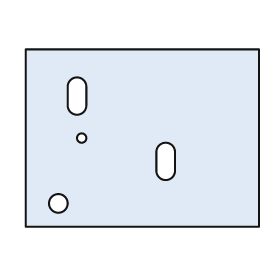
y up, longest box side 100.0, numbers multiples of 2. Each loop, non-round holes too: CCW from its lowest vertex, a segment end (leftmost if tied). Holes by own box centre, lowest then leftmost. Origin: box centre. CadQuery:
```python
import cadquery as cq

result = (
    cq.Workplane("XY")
    .moveTo(-50.0, -38.0)
    .lineTo(50.0, -38.0)
    .lineTo(50.0, 38.0)
    .lineTo(-50.0, 38.0)
    .close()
    .moveTo(-36.0, -28.0)
    .circle(4.0)
    .moveTo(6.0, -14.0)
    .threePointArc((10.0, -18.0), (14.0, -14.0))
    .lineTo(14.0, -6.0)
    .threePointArc((10.0, -2.0), (6.0, -6.0))
    .close()
    .moveTo(-26.0, 0.0)
    .circle(2.0)
    .moveTo(-32.0, 14.0)
    .threePointArc((-28.0, 10.0), (-24.0, 14.0))
    .lineTo(-24.0, 22.0)
    .threePointArc((-28.0, 26.0), (-32.0, 22.0))
    .close()
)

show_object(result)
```